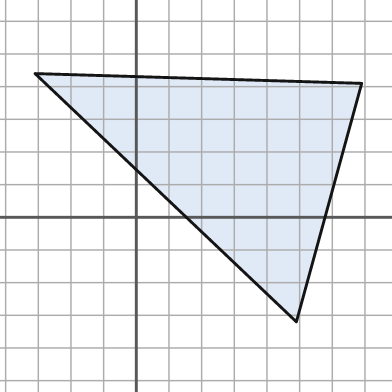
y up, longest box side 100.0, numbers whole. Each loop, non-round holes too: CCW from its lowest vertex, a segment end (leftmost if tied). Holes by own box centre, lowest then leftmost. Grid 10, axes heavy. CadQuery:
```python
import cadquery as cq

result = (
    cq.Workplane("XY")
    .moveTo(49.0, -32.0)
    .lineTo(69.0, 41.0)
    .lineTo(-31.0, 44.0)
    .close()
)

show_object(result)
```